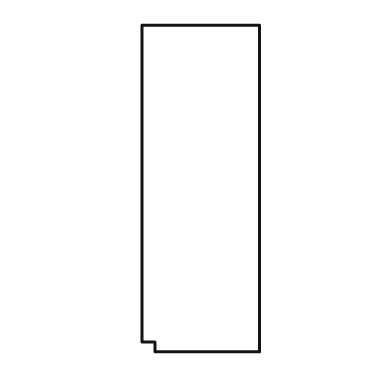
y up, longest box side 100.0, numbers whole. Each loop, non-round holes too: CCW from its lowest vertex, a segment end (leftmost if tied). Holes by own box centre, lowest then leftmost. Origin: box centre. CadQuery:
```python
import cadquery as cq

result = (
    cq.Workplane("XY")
    .moveTo(-14.0, -50.0)
    .lineTo(18.0, -50.0)
    .lineTo(18.0, 50.0)
    .lineTo(-18.0, 50.0)
    .lineTo(-18.0, -47.0)
    .lineTo(-14.0, -47.0)
    .close()
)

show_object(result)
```